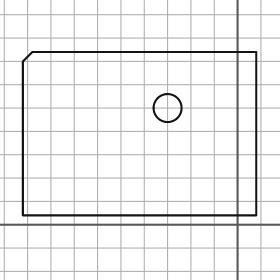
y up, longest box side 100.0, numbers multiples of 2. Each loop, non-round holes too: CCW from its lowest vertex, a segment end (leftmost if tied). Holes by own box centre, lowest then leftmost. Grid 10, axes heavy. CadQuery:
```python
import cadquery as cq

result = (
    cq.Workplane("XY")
    .moveTo(-92.0, 4.0)
    .lineTo(8.0, 4.0)
    .lineTo(8.0, 74.0)
    .lineTo(-88.0, 74.0)
    .lineTo(-92.0, 70.0)
    .close()
    .moveTo(-30.0, 50.0)
    .circle(6.0)
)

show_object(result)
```